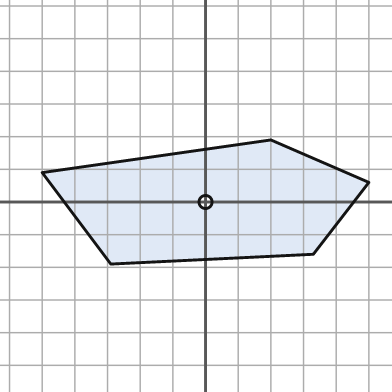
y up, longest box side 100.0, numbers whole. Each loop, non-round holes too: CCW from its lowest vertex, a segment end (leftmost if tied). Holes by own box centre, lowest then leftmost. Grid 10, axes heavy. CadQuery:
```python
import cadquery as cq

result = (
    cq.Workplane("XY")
    .moveTo(-29.0, -19.0)
    .lineTo(33.0, -16.0)
    .lineTo(50.0, 6.0)
    .lineTo(20.0, 19.0)
    .lineTo(-50.0, 9.0)
    .close()
    .moveTo(0.0, 0.0)
    .circle(2.0)
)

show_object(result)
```